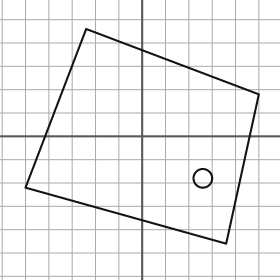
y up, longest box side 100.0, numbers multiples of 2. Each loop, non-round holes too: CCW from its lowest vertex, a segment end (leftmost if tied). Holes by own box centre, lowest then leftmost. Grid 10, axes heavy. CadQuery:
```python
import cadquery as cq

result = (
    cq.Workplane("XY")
    .moveTo(36.0, -46.0)
    .lineTo(50.0, 18.0)
    .lineTo(-24.0, 46.0)
    .lineTo(-50.0, -22.0)
    .close()
    .moveTo(26.0, -18.0)
    .circle(4.0)
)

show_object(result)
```